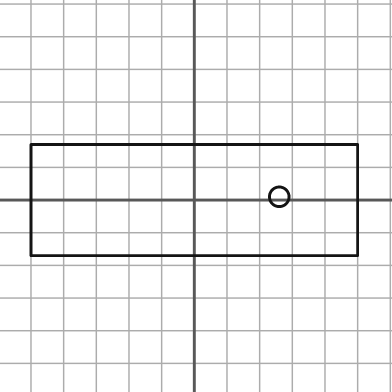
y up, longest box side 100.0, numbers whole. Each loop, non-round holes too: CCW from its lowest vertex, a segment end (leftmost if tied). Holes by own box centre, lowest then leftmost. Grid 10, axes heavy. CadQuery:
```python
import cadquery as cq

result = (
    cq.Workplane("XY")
    .moveTo(-50.0, -17.0)
    .lineTo(50.0, -17.0)
    .lineTo(50.0, 17.0)
    .lineTo(-50.0, 17.0)
    .close()
    .moveTo(26.0, 1.0)
    .circle(3.0)
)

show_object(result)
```